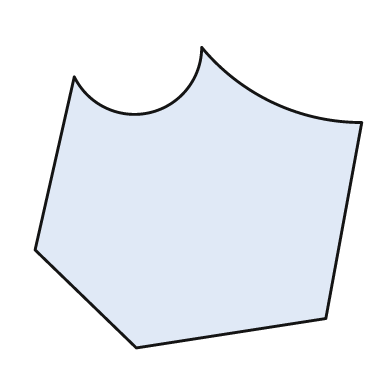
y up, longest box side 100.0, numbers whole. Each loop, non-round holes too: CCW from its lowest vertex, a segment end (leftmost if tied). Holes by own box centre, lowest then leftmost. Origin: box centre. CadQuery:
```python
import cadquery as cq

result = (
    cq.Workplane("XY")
    .moveTo(-19.0, -46.0)
    .lineTo(39.0, -37.0)
    .lineTo(50.0, 23.0)
    .threePointArc((23.0, 29.0), (1.0, 46.0))
    .threePointArc((-15.0, 26.0), (-38.0, 37.0))
    .lineTo(-50.0, -16.0)
    .close()
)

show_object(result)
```